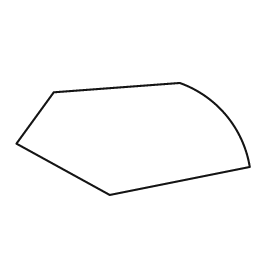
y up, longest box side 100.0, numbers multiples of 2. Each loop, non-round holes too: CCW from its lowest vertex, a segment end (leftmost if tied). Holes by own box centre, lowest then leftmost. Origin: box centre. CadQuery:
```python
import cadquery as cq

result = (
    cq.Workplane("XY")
    .moveTo(-10.0, -24.0)
    .lineTo(50.0, -12.0)
    .threePointArc((40.0, 10.0), (20.0, 24.0))
    .lineTo(-34.0, 20.0)
    .lineTo(-50.0, -2.0)
    .close()
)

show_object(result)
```